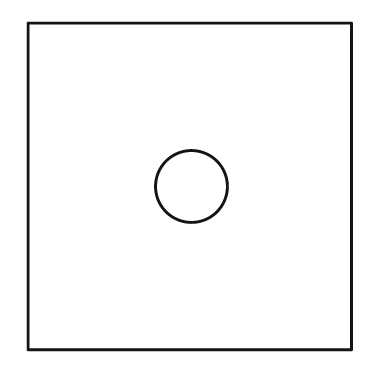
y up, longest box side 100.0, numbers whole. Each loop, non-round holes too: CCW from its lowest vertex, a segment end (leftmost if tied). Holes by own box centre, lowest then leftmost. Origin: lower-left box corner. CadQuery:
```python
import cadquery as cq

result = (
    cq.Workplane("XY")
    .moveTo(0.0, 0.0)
    .lineTo(99.0, 0.0)
    .lineTo(99.0, 100.0)
    .lineTo(0.0, 100.0)
    .close()
    .moveTo(50.0, 50.0)
    .circle(11.0)
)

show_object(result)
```